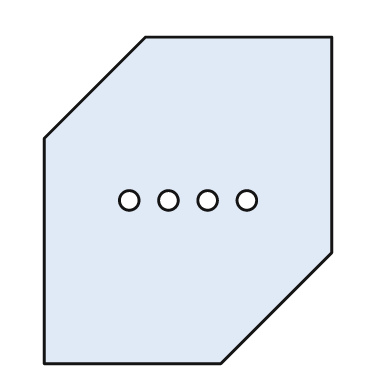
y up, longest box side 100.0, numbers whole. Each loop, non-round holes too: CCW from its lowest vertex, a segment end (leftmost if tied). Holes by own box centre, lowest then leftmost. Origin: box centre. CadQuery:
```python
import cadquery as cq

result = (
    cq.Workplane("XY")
    .moveTo(-44.0, -50.0)
    .lineTo(10.0, -50.0)
    .lineTo(44.0, -16.0)
    .lineTo(44.0, 50.0)
    .lineTo(-13.0, 50.0)
    .lineTo(-44.0, 19.0)
    .close()
    .moveTo(-18.0, 0.0)
    .circle(3.0)
    .moveTo(-6.0, 0.0)
    .circle(3.0)
    .moveTo(6.0, 0.0)
    .circle(3.0)
    .moveTo(18.0, 0.0)
    .circle(3.0)
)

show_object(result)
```